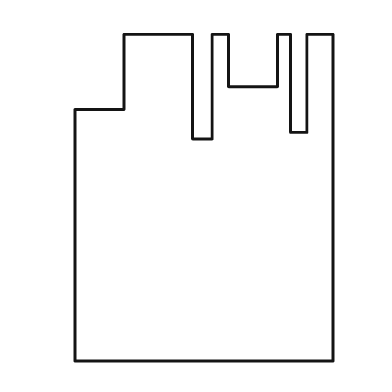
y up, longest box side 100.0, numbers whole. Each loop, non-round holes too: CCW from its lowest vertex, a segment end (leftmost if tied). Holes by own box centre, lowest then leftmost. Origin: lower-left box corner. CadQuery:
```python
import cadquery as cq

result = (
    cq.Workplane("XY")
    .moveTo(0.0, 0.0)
    .lineTo(79.0, 0.0)
    .lineTo(79.0, 100.0)
    .lineTo(71.0, 100.0)
    .lineTo(71.0, 70.0)
    .lineTo(66.0, 70.0)
    .lineTo(66.0, 100.0)
    .lineTo(62.0, 100.0)
    .lineTo(62.0, 84.0)
    .lineTo(47.0, 84.0)
    .lineTo(47.0, 100.0)
    .lineTo(42.0, 100.0)
    .lineTo(42.0, 68.0)
    .lineTo(36.0, 68.0)
    .lineTo(36.0, 100.0)
    .lineTo(15.0, 100.0)
    .lineTo(15.0, 77.0)
    .lineTo(0.0, 77.0)
    .close()
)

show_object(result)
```